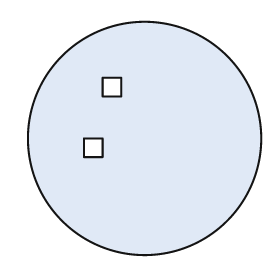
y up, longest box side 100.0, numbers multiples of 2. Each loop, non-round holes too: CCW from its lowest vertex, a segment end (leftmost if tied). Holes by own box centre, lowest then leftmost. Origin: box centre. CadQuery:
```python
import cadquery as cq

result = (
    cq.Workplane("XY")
    .moveTo(0.0, 0.0)
    .circle(50.0)
    .moveTo(-26.0, -8.0)
    .lineTo(-18.0, -8.0)
    .lineTo(-18.0, 0.0)
    .lineTo(-26.0, 0.0)
    .close()
    .moveTo(-18.0, 18.0)
    .lineTo(-10.0, 18.0)
    .lineTo(-10.0, 26.0)
    .lineTo(-18.0, 26.0)
    .close()
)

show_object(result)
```